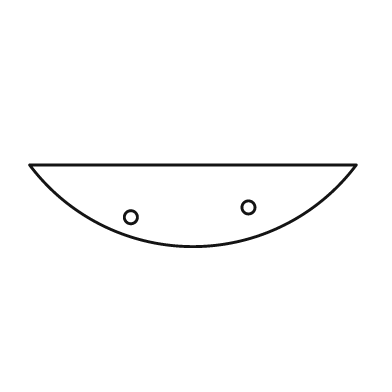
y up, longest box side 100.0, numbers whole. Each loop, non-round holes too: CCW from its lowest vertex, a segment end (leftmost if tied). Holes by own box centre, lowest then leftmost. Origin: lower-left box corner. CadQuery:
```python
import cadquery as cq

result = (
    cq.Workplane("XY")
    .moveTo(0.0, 25.0)
    .threePointArc((50.0, 0.0), (100.0, 25.0))
    .close()
    .moveTo(31.0, 9.0)
    .circle(2.0)
    .moveTo(67.0, 12.0)
    .circle(2.0)
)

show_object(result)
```